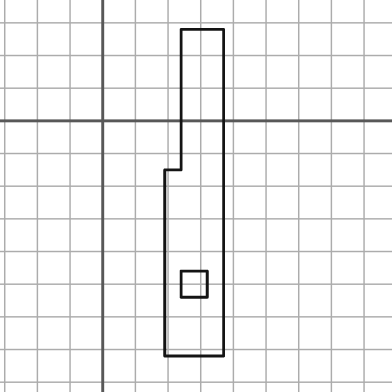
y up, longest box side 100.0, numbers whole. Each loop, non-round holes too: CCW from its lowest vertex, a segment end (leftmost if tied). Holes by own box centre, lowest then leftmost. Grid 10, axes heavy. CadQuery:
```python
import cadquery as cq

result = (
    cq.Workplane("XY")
    .moveTo(19.0, -72.0)
    .lineTo(37.0, -72.0)
    .lineTo(37.0, 28.0)
    .lineTo(24.0, 28.0)
    .lineTo(24.0, -15.0)
    .lineTo(19.0, -15.0)
    .close()
    .moveTo(24.0, -54.0)
    .lineTo(32.0, -54.0)
    .lineTo(32.0, -46.0)
    .lineTo(24.0, -46.0)
    .close()
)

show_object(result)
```